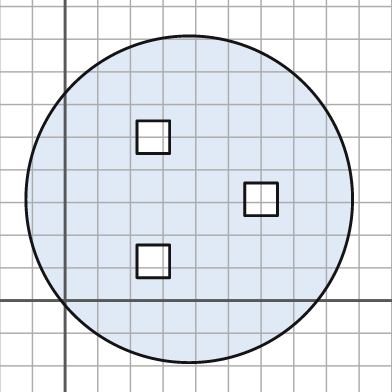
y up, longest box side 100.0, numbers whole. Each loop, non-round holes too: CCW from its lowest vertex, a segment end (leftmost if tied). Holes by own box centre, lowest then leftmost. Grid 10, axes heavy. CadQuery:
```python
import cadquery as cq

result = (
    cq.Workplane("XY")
    .moveTo(38.0, 31.0)
    .circle(50.0)
    .moveTo(22.0, 7.0)
    .lineTo(32.0, 7.0)
    .lineTo(32.0, 17.0)
    .lineTo(22.0, 17.0)
    .close()
    .moveTo(55.0, 26.0)
    .lineTo(65.0, 26.0)
    .lineTo(65.0, 36.0)
    .lineTo(55.0, 36.0)
    .close()
    .moveTo(22.0, 45.0)
    .lineTo(32.0, 45.0)
    .lineTo(32.0, 55.0)
    .lineTo(22.0, 55.0)
    .close()
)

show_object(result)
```